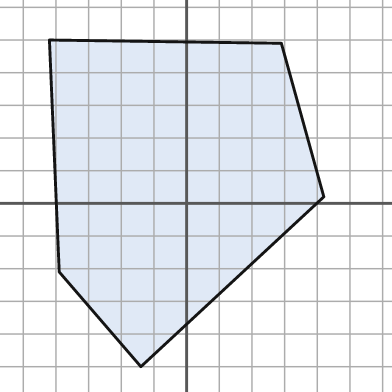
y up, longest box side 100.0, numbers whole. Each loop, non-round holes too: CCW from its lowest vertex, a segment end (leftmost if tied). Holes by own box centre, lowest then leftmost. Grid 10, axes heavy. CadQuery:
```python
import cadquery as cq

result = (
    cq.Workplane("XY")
    .moveTo(-14.0, -50.0)
    .lineTo(42.0, 2.0)
    .lineTo(29.0, 49.0)
    .lineTo(-42.0, 50.0)
    .lineTo(-39.0, -21.0)
    .close()
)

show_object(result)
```